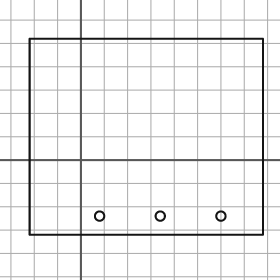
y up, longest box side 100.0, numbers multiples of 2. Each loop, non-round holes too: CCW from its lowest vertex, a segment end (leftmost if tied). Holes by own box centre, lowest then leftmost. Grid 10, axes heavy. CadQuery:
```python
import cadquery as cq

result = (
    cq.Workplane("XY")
    .moveTo(-22.0, -32.0)
    .lineTo(78.0, -32.0)
    .lineTo(78.0, 52.0)
    .lineTo(-22.0, 52.0)
    .close()
    .moveTo(8.0, -24.0)
    .circle(2.0)
    .moveTo(34.0, -24.0)
    .circle(2.0)
    .moveTo(60.0, -24.0)
    .circle(2.0)
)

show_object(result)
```